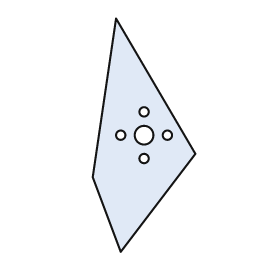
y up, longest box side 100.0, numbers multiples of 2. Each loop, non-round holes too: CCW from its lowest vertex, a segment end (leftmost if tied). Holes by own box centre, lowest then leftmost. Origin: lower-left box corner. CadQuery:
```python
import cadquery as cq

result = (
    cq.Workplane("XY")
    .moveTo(12.0, 0.0)
    .lineTo(44.0, 42.0)
    .lineTo(10.0, 100.0)
    .lineTo(0.0, 32.0)
    .close()
    .moveTo(22.0, 40.0)
    .circle(2.0)
    .moveTo(12.0, 50.0)
    .circle(2.0)
    .moveTo(22.0, 50.0)
    .circle(4.0)
    .moveTo(32.0, 50.0)
    .circle(2.0)
    .moveTo(22.0, 60.0)
    .circle(2.0)
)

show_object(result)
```